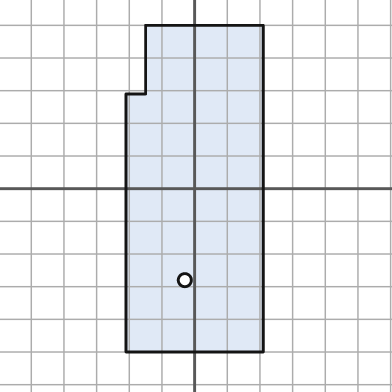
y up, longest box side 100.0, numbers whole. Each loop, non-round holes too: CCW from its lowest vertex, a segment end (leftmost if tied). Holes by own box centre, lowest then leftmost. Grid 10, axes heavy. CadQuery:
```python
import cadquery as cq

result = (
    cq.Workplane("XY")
    .moveTo(-21.0, -50.0)
    .lineTo(21.0, -50.0)
    .lineTo(21.0, 50.0)
    .lineTo(-15.0, 50.0)
    .lineTo(-15.0, 29.0)
    .lineTo(-21.0, 29.0)
    .close()
    .moveTo(-3.0, -28.0)
    .circle(2.0)
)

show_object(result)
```